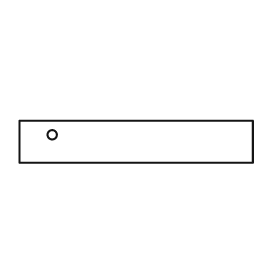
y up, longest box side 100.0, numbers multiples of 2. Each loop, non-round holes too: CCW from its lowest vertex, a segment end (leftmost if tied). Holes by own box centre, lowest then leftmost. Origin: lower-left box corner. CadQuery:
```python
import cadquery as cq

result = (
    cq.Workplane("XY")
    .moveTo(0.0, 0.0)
    .lineTo(100.0, 0.0)
    .lineTo(100.0, 18.0)
    .lineTo(0.0, 18.0)
    .close()
    .moveTo(14.0, 12.0)
    .circle(2.0)
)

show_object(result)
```